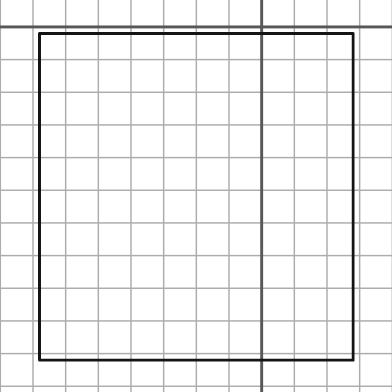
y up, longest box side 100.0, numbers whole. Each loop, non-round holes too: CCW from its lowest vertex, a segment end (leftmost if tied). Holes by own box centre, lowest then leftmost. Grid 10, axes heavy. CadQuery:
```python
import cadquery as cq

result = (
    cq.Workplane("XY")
    .moveTo(-68.0, -102.0)
    .lineTo(28.0, -102.0)
    .lineTo(28.0, -2.0)
    .lineTo(-68.0, -2.0)
    .close()
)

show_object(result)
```